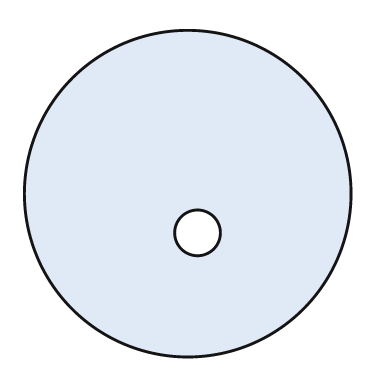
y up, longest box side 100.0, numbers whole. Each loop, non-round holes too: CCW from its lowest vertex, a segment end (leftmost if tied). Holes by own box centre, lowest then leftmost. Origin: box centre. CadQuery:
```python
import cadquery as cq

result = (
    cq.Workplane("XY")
    .moveTo(0.0, 0.0)
    .circle(50.0)
    .moveTo(3.0, -12.0)
    .circle(7.0)
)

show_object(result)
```